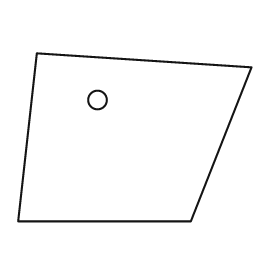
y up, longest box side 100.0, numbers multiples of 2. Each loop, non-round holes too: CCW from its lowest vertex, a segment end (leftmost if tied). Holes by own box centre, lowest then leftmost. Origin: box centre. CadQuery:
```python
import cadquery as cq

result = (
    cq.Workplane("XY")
    .moveTo(-50.0, -36.0)
    .lineTo(24.0, -36.0)
    .lineTo(50.0, 30.0)
    .lineTo(-42.0, 36.0)
    .close()
    .moveTo(-16.0, 16.0)
    .circle(4.0)
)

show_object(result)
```